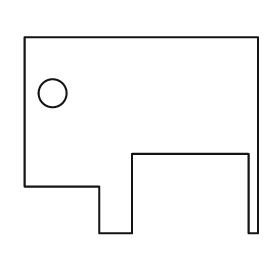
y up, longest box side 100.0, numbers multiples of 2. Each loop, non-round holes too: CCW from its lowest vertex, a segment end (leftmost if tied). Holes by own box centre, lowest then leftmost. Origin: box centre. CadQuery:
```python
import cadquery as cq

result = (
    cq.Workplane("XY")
    .moveTo(-18.0, -42.0)
    .lineTo(-4.0, -42.0)
    .lineTo(-4.0, -8.0)
    .lineTo(46.0, -8.0)
    .lineTo(46.0, -42.0)
    .lineTo(50.0, -42.0)
    .lineTo(50.0, 42.0)
    .lineTo(-50.0, 42.0)
    .lineTo(-50.0, -22.0)
    .lineTo(-18.0, -22.0)
    .close()
    .moveTo(-38.0, 18.0)
    .circle(6.0)
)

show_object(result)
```